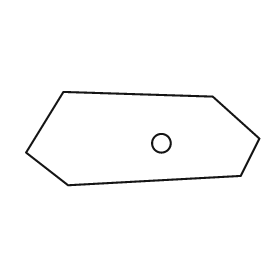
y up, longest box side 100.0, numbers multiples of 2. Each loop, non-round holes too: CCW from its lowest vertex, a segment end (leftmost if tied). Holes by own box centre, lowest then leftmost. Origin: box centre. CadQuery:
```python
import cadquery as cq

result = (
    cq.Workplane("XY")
    .moveTo(-32.0, -20.0)
    .lineTo(42.0, -16.0)
    .lineTo(50.0, 0.0)
    .lineTo(30.0, 18.0)
    .lineTo(-34.0, 20.0)
    .lineTo(-50.0, -6.0)
    .close()
    .moveTo(8.0, -2.0)
    .circle(4.0)
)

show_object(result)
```